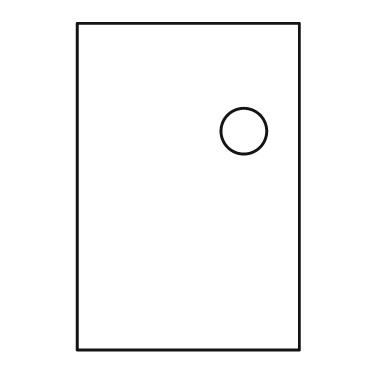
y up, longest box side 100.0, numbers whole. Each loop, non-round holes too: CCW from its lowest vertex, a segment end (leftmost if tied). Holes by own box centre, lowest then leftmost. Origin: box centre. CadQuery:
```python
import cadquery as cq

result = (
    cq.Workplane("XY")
    .moveTo(-34.0, -50.0)
    .lineTo(34.0, -50.0)
    .lineTo(34.0, 50.0)
    .lineTo(-34.0, 50.0)
    .close()
    .moveTo(17.0, 17.0)
    .circle(7.0)
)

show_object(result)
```